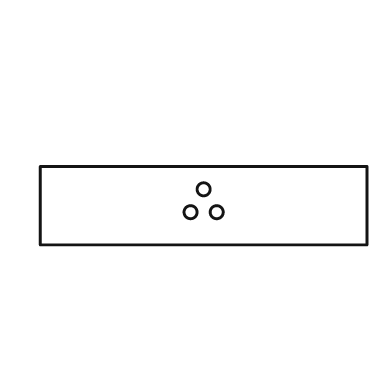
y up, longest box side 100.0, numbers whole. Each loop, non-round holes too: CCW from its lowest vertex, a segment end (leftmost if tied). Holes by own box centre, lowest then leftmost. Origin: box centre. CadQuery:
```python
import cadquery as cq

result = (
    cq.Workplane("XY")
    .moveTo(-50.0, -12.0)
    .lineTo(50.0, -12.0)
    .lineTo(50.0, 12.0)
    .lineTo(-50.0, 12.0)
    .close()
    .moveTo(-4.0, -2.0)
    .circle(2.0)
    .moveTo(4.0, -2.0)
    .circle(2.0)
    .moveTo(0.0, 5.0)
    .circle(2.0)
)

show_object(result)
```